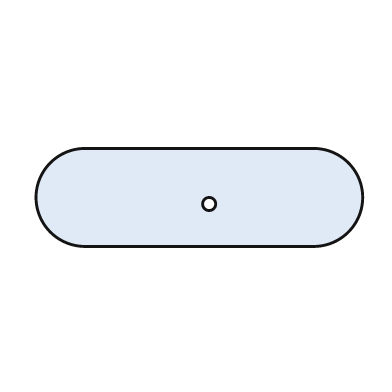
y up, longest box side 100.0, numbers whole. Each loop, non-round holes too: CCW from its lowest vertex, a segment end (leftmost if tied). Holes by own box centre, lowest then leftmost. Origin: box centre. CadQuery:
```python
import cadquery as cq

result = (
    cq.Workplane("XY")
    .moveTo(-35.0, -15.0)
    .lineTo(35.0, -15.0)
    .threePointArc((50.0, 0.0), (35.0, 15.0))
    .lineTo(-35.0, 15.0)
    .threePointArc((-50.0, 0.0), (-35.0, -15.0))
    .close()
    .moveTo(3.0, -2.0)
    .circle(2.0)
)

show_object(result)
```